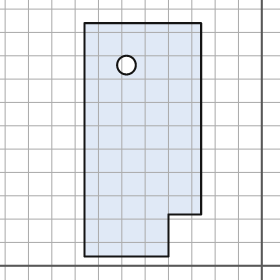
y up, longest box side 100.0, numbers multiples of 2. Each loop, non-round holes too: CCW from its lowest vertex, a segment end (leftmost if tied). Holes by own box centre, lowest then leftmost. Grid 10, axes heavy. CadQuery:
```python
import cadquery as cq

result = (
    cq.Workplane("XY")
    .moveTo(-76.0, 4.0)
    .lineTo(-40.0, 4.0)
    .lineTo(-40.0, 22.0)
    .lineTo(-26.0, 22.0)
    .lineTo(-26.0, 104.0)
    .lineTo(-76.0, 104.0)
    .close()
    .moveTo(-58.0, 86.0)
    .circle(4.0)
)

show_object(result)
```